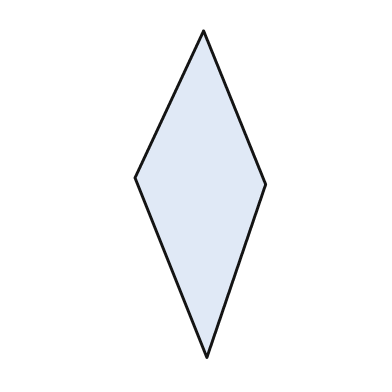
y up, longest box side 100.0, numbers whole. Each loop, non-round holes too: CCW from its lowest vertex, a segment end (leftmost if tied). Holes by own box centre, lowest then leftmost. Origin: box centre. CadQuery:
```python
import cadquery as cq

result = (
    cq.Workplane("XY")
    .moveTo(2.0, -50.0)
    .lineTo(20.0, 3.0)
    .lineTo(1.0, 50.0)
    .lineTo(-20.0, 5.0)
    .close()
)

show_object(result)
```